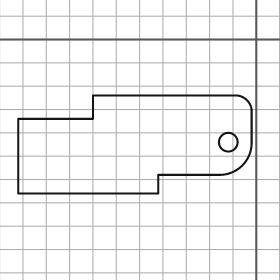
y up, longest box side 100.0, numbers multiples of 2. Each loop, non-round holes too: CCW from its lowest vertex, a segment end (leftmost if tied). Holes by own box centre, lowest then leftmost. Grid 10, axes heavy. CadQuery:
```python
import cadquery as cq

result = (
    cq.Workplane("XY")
    .moveTo(-102.0, -66.0)
    .lineTo(-42.0, -66.0)
    .lineTo(-42.0, -58.0)
    .lineTo(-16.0, -58.0)
    .threePointArc((-6.0, -54.0), (-2.0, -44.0))
    .lineTo(-2.0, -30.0)
    .threePointArc((-4.0, -26.0), (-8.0, -24.0))
    .lineTo(-70.0, -24.0)
    .lineTo(-70.0, -34.0)
    .lineTo(-102.0, -34.0)
    .close()
    .moveTo(-12.0, -44.0)
    .circle(4.0)
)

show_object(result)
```